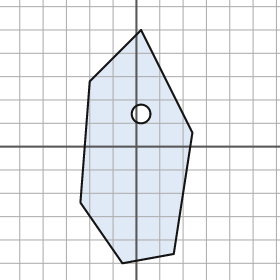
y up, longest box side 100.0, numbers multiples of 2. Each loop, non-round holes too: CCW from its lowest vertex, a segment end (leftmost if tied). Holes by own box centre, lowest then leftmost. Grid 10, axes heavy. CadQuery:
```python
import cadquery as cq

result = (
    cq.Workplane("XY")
    .moveTo(-6.0, -50.0)
    .lineTo(16.0, -46.0)
    .lineTo(24.0, 6.0)
    .lineTo(2.0, 50.0)
    .lineTo(-20.0, 28.0)
    .lineTo(-24.0, -24.0)
    .close()
    .moveTo(2.0, 14.0)
    .circle(4.0)
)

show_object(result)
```